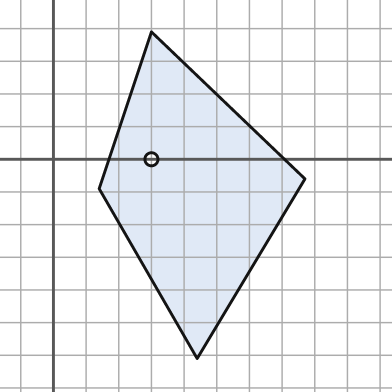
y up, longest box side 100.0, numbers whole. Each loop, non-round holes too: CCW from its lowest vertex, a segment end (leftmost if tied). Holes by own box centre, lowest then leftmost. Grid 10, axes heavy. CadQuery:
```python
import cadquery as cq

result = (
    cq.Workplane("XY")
    .moveTo(44.0, -61.0)
    .lineTo(77.0, -6.0)
    .lineTo(30.0, 39.0)
    .lineTo(14.0, -9.0)
    .close()
    .moveTo(30.0, 0.0)
    .circle(2.0)
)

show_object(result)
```